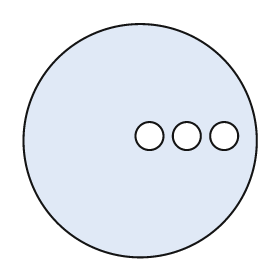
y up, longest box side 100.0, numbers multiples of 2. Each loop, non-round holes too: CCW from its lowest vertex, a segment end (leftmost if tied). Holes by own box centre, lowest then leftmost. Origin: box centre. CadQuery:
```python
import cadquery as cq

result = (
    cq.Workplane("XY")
    .moveTo(0.0, 0.0)
    .circle(50.0)
    .moveTo(4.0, 2.0)
    .circle(6.0)
    .moveTo(20.0, 2.0)
    .circle(6.0)
    .moveTo(36.0, 2.0)
    .circle(6.0)
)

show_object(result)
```